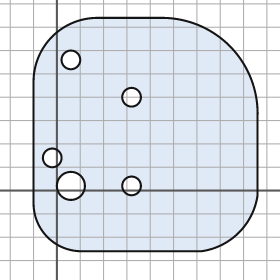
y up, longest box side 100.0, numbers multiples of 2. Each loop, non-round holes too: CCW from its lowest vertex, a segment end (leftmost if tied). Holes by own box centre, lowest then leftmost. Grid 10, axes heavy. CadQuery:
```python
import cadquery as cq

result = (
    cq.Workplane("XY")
    .moveTo(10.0, -26.0)
    .lineTo(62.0, -26.0)
    .threePointArc((78.0, -18.0), (86.0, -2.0))
    .lineTo(86.0, 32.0)
    .threePointArc((74.0, 62.0), (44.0, 74.0))
    .lineTo(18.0, 74.0)
    .threePointArc((-2.0, 66.0), (-10.0, 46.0))
    .lineTo(-10.0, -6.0)
    .threePointArc((-4.0, -20.0), (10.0, -26.0))
    .close()
    .moveTo(6.0, 2.0)
    .circle(6.0)
    .moveTo(32.0, 2.0)
    .circle(4.0)
    .moveTo(-2.0, 14.0)
    .circle(4.0)
    .moveTo(32.0, 40.0)
    .circle(4.0)
    .moveTo(6.0, 56.0)
    .circle(4.0)
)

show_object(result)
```